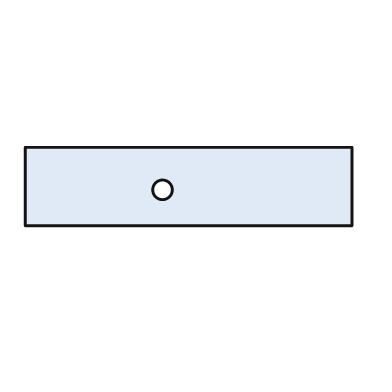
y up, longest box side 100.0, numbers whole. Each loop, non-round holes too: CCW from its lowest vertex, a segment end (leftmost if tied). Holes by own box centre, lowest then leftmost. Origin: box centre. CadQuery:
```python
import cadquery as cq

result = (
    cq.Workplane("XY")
    .moveTo(-50.0, -12.0)
    .lineTo(50.0, -12.0)
    .lineTo(50.0, 12.0)
    .lineTo(-50.0, 12.0)
    .close()
    .moveTo(-8.0, -1.0)
    .circle(3.0)
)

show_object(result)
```